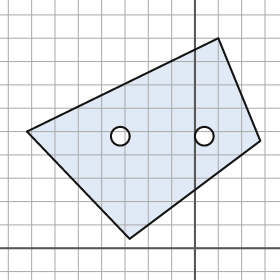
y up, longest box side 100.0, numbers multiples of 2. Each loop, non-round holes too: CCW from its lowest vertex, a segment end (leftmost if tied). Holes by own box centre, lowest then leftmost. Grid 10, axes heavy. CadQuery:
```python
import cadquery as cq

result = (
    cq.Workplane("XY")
    .moveTo(-28.0, 4.0)
    .lineTo(28.0, 46.0)
    .lineTo(10.0, 90.0)
    .lineTo(-72.0, 50.0)
    .close()
    .moveTo(-32.0, 48.0)
    .circle(4.0)
    .moveTo(4.0, 48.0)
    .circle(4.0)
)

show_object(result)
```